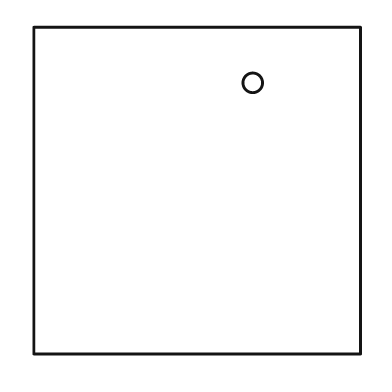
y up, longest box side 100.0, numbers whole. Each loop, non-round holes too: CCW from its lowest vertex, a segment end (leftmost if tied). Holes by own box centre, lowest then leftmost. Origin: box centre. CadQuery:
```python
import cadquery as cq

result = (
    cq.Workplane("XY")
    .moveTo(-50.0, -50.0)
    .lineTo(50.0, -50.0)
    .lineTo(50.0, 50.0)
    .lineTo(-50.0, 50.0)
    .close()
    .moveTo(17.0, 33.0)
    .circle(3.0)
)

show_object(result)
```